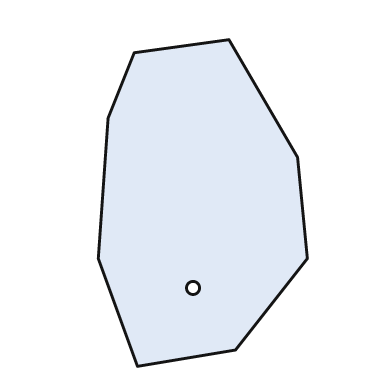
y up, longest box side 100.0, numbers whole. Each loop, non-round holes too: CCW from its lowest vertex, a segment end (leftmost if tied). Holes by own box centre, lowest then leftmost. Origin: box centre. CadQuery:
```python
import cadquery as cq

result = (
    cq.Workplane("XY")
    .moveTo(-20.0, -50.0)
    .lineTo(10.0, -45.0)
    .lineTo(32.0, -17.0)
    .lineTo(29.0, 14.0)
    .lineTo(8.0, 50.0)
    .lineTo(-21.0, 46.0)
    .lineTo(-29.0, 26.0)
    .lineTo(-32.0, -17.0)
    .close()
    .moveTo(-3.0, -26.0)
    .circle(2.0)
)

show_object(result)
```